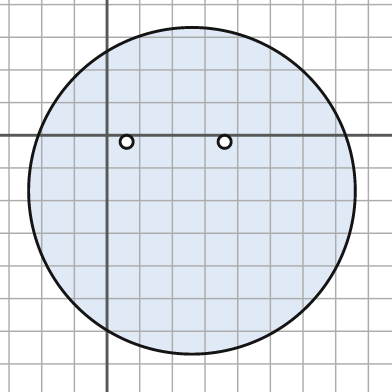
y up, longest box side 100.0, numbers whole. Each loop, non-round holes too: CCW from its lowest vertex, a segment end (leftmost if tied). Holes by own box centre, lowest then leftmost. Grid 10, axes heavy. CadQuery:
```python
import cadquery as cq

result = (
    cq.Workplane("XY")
    .moveTo(26.0, -17.0)
    .circle(50.0)
    .moveTo(6.0, -2.0)
    .circle(2.0)
    .moveTo(36.0, -2.0)
    .circle(2.0)
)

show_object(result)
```